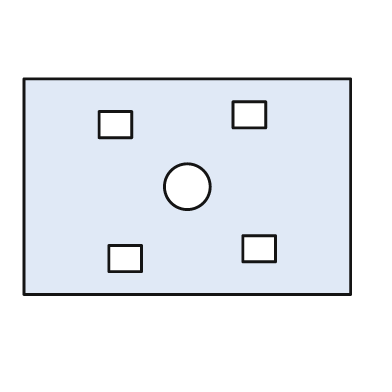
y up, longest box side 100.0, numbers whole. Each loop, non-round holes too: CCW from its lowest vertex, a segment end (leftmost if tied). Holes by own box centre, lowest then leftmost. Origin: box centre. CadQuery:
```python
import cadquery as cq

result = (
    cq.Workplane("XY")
    .moveTo(-50.0, -33.0)
    .lineTo(50.0, -33.0)
    .lineTo(50.0, 33.0)
    .lineTo(-50.0, 33.0)
    .close()
    .moveTo(-24.0, -26.0)
    .lineTo(-14.0, -26.0)
    .lineTo(-14.0, -18.0)
    .lineTo(-24.0, -18.0)
    .close()
    .moveTo(17.0, -23.0)
    .lineTo(27.0, -23.0)
    .lineTo(27.0, -15.0)
    .lineTo(17.0, -15.0)
    .close()
    .moveTo(0.0, 0.0)
    .circle(7.0)
    .moveTo(-27.0, 15.0)
    .lineTo(-17.0, 15.0)
    .lineTo(-17.0, 23.0)
    .lineTo(-27.0, 23.0)
    .close()
    .moveTo(14.0, 18.0)
    .lineTo(24.0, 18.0)
    .lineTo(24.0, 26.0)
    .lineTo(14.0, 26.0)
    .close()
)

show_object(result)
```